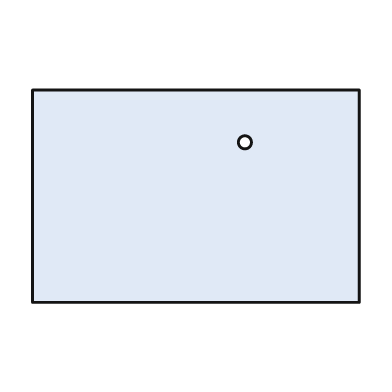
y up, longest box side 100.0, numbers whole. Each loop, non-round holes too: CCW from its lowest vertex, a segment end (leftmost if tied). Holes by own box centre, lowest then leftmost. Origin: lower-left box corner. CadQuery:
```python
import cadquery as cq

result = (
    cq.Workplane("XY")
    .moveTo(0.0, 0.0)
    .lineTo(100.0, 0.0)
    .lineTo(100.0, 65.0)
    .lineTo(0.0, 65.0)
    .close()
    .moveTo(65.0, 49.0)
    .circle(2.0)
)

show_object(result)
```